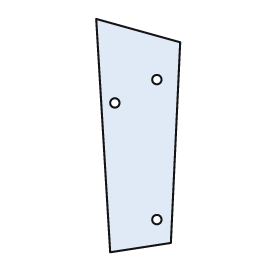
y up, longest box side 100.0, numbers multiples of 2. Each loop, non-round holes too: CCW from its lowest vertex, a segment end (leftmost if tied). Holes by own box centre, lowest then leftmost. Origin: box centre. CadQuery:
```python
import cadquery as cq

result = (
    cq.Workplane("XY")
    .moveTo(-12.0, -50.0)
    .lineTo(14.0, -46.0)
    .lineTo(18.0, 40.0)
    .lineTo(-18.0, 50.0)
    .close()
    .moveTo(8.0, -36.0)
    .circle(2.0)
    .moveTo(-10.0, 14.0)
    .circle(2.0)
    .moveTo(8.0, 24.0)
    .circle(2.0)
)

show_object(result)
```